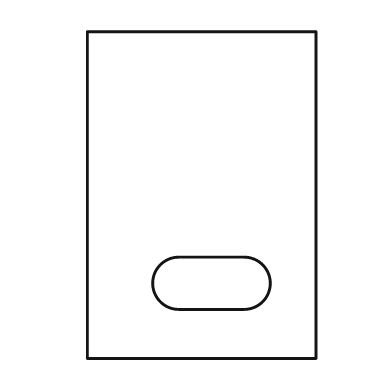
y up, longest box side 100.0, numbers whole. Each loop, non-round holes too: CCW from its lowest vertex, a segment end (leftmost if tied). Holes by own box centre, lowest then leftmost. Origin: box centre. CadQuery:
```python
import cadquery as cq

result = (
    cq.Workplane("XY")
    .moveTo(-35.0, -50.0)
    .lineTo(35.0, -50.0)
    .lineTo(35.0, 50.0)
    .lineTo(-35.0, 50.0)
    .close()
    .moveTo(-7.0, -35.0)
    .lineTo(13.0, -35.0)
    .threePointArc((21.0, -27.0), (13.0, -19.0))
    .lineTo(-7.0, -19.0)
    .threePointArc((-15.0, -27.0), (-7.0, -35.0))
    .close()
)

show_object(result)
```